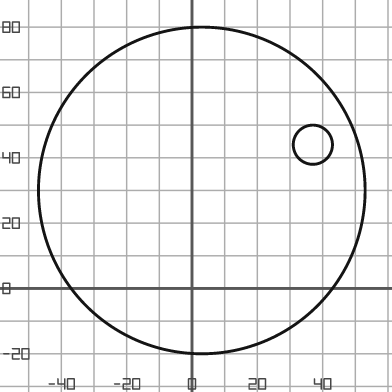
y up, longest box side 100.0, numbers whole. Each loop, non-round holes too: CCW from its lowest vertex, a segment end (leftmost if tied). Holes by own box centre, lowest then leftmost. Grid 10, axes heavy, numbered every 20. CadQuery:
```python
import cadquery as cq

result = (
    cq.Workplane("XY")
    .moveTo(3.0, 30.0)
    .circle(50.0)
    .moveTo(37.0, 44.0)
    .circle(6.0)
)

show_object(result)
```